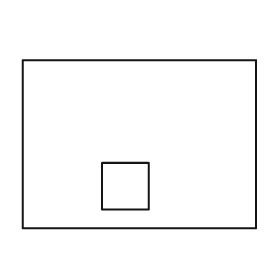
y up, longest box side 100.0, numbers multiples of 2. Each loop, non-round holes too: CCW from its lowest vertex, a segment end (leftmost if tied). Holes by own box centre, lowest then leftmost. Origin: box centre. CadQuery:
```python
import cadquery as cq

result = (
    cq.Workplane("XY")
    .moveTo(-50.0, -36.0)
    .lineTo(50.0, -36.0)
    .lineTo(50.0, 36.0)
    .lineTo(-50.0, 36.0)
    .close()
    .moveTo(-16.0, -28.0)
    .lineTo(4.0, -28.0)
    .lineTo(4.0, -8.0)
    .lineTo(-16.0, -8.0)
    .close()
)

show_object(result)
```